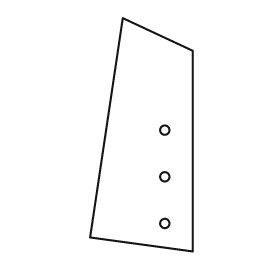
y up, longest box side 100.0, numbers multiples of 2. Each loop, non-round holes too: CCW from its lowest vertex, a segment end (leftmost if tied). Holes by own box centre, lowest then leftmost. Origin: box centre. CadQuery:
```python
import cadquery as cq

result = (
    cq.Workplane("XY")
    .moveTo(22.0, -50.0)
    .lineTo(22.0, 36.0)
    .lineTo(-8.0, 50.0)
    .lineTo(-22.0, -44.0)
    .close()
    .moveTo(10.0, -38.0)
    .circle(2.0)
    .moveTo(10.0, -18.0)
    .circle(2.0)
    .moveTo(10.0, 2.0)
    .circle(2.0)
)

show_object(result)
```